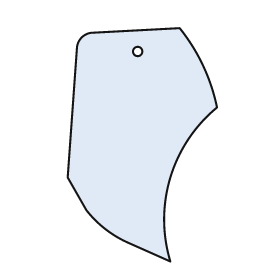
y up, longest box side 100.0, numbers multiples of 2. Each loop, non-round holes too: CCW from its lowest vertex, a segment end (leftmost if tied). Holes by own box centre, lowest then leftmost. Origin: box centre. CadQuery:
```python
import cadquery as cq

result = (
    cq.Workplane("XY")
    .moveTo(12.0, -50.0)
    .threePointArc((12.0, -14.0), (32.0, 16.0))
    .threePointArc((26.0, 34.0), (16.0, 50.0))
    .lineTo(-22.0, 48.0)
    .threePointArc((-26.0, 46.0), (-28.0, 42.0))
    .lineTo(-32.0, -14.0)
    .lineTo(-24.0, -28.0)
    .threePointArc((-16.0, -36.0), (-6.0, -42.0))
    .close()
    .moveTo(-2.0, 40.0)
    .circle(2.0)
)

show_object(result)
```